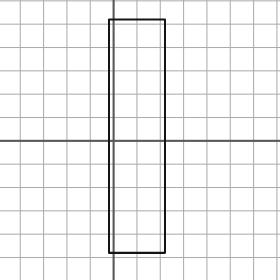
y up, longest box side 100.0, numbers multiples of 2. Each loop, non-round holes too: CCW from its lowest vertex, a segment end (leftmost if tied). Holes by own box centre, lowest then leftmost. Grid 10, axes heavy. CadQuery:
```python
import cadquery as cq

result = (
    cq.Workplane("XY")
    .moveTo(-2.0, -48.0)
    .lineTo(22.0, -48.0)
    .lineTo(22.0, 52.0)
    .lineTo(-2.0, 52.0)
    .close()
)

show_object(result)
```